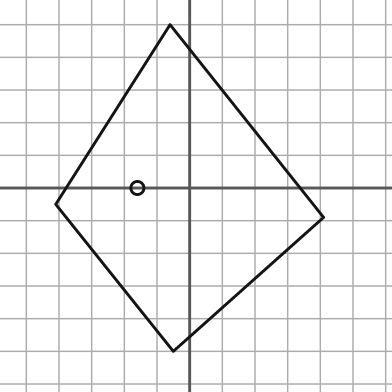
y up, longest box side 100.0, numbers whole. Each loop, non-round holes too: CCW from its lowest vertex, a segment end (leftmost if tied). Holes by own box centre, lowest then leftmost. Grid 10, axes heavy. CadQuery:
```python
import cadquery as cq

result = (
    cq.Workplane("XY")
    .moveTo(-5.0, -50.0)
    .lineTo(41.0, -9.0)
    .lineTo(-6.0, 50.0)
    .lineTo(-41.0, -5.0)
    .close()
    .moveTo(-16.0, 0.0)
    .circle(2.0)
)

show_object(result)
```